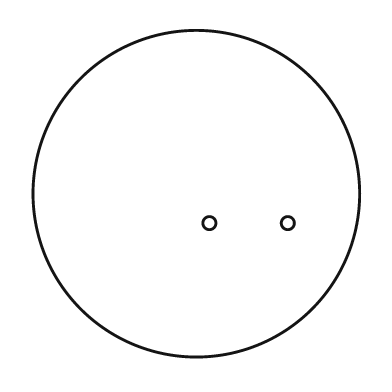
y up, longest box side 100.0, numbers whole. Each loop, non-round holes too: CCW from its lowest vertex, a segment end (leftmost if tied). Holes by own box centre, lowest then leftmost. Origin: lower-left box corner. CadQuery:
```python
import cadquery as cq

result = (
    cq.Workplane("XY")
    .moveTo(50.0, 50.0)
    .circle(50.0)
    .moveTo(54.0, 41.0)
    .circle(2.0)
    .moveTo(78.0, 41.0)
    .circle(2.0)
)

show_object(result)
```